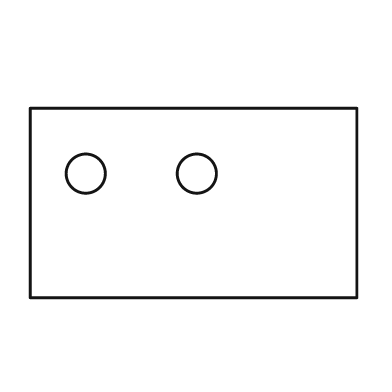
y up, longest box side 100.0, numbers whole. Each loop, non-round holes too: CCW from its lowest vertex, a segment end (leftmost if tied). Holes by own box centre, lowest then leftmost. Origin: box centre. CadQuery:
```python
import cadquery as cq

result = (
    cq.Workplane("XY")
    .moveTo(-50.0, -29.0)
    .lineTo(50.0, -29.0)
    .lineTo(50.0, 29.0)
    .lineTo(-50.0, 29.0)
    .close()
    .moveTo(-33.0, 9.0)
    .circle(6.0)
    .moveTo(1.0, 9.0)
    .circle(6.0)
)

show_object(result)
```